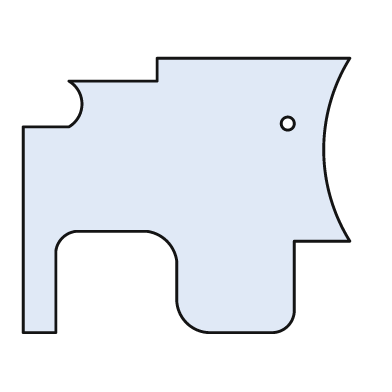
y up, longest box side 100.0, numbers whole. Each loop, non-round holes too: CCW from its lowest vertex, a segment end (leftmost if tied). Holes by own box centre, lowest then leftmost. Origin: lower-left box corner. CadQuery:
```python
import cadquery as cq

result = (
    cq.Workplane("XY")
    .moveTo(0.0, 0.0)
    .lineTo(10.0, 0.0)
    .lineTo(10.0, 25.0)
    .threePointArc((12.0, 29.0), (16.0, 31.0))
    .lineTo(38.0, 31.0)
    .threePointArc((44.0, 28.0), (47.0, 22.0))
    .lineTo(47.0, 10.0)
    .threePointArc((50.0, 3.0), (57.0, 0.0))
    .lineTo(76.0, 0.0)
    .threePointArc((81.0, 2.0), (83.0, 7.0))
    .lineTo(83.0, 28.0)
    .lineTo(100.0, 28.0)
    .threePointArc((92.0, 56.0), (100.0, 84.0))
    .lineTo(41.0, 84.0)
    .lineTo(41.0, 77.0)
    .lineTo(14.0, 77.0)
    .threePointArc((18.0, 70.0), (14.0, 63.0))
    .lineTo(0.0, 63.0)
    .close()
    .moveTo(81.0, 64.0)
    .circle(2.0)
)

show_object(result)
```